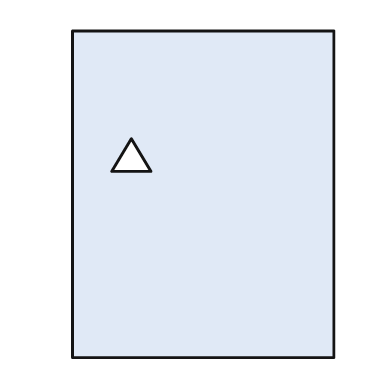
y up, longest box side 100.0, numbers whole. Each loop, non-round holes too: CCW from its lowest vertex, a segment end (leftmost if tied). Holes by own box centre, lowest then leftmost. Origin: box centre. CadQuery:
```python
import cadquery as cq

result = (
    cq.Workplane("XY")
    .moveTo(-40.0, -50.0)
    .lineTo(40.0, -50.0)
    .lineTo(40.0, 50.0)
    .lineTo(-40.0, 50.0)
    .close()
    .moveTo(-28.0, 7.0)
    .lineTo(-16.0, 7.0)
    .lineTo(-22.0, 17.0)
    .close()
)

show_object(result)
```